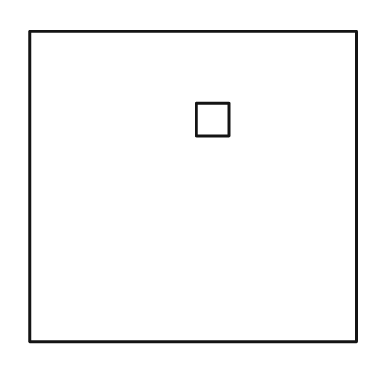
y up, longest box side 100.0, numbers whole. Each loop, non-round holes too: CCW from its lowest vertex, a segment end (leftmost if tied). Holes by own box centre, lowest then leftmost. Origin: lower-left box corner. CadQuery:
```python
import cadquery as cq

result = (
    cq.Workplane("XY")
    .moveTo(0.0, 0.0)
    .lineTo(100.0, 0.0)
    .lineTo(100.0, 95.0)
    .lineTo(0.0, 95.0)
    .close()
    .moveTo(51.0, 63.0)
    .lineTo(61.0, 63.0)
    .lineTo(61.0, 73.0)
    .lineTo(51.0, 73.0)
    .close()
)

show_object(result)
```